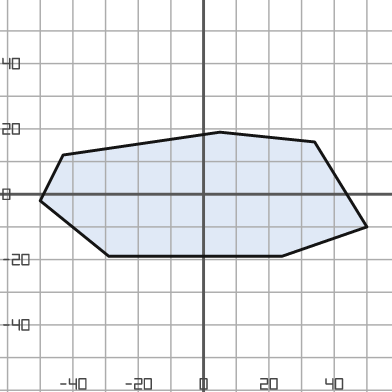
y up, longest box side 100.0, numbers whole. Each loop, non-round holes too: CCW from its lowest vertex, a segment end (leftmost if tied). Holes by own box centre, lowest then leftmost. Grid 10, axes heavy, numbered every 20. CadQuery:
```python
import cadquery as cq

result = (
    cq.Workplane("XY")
    .moveTo(-29.0, -19.0)
    .lineTo(24.0, -19.0)
    .lineTo(50.0, -10.0)
    .lineTo(34.0, 16.0)
    .lineTo(5.0, 19.0)
    .lineTo(-43.0, 12.0)
    .lineTo(-50.0, -2.0)
    .close()
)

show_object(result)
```